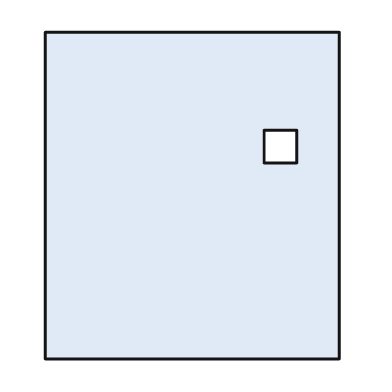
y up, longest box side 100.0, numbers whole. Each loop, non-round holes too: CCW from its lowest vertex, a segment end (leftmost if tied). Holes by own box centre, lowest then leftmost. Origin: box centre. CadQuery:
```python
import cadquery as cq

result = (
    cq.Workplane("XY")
    .moveTo(-45.0, -50.0)
    .lineTo(45.0, -50.0)
    .lineTo(45.0, 50.0)
    .lineTo(-45.0, 50.0)
    .close()
    .moveTo(22.0, 10.0)
    .lineTo(32.0, 10.0)
    .lineTo(32.0, 20.0)
    .lineTo(22.0, 20.0)
    .close()
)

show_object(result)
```